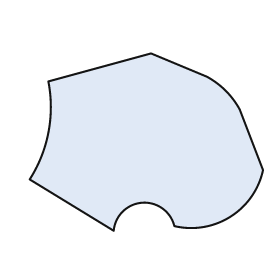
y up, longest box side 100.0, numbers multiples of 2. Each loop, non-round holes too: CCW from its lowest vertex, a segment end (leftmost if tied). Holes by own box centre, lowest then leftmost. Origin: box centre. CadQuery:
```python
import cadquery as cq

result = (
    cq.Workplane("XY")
    .moveTo(-14.0, -38.0)
    .threePointArc((-2.0, -26.0), (12.0, -36.0))
    .threePointArc((36.0, -32.0), (50.0, -12.0))
    .lineTo(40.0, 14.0)
    .threePointArc((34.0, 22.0), (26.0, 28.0))
    .lineTo(2.0, 38.0)
    .lineTo(-42.0, 26.0)
    .threePointArc((-42.0, 4.0), (-50.0, -16.0))
    .close()
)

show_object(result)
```